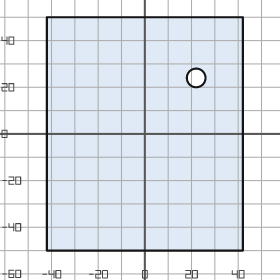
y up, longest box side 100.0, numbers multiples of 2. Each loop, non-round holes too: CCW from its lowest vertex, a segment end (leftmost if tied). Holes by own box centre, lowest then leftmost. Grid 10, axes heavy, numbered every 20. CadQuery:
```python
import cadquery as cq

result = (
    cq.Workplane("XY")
    .moveTo(-42.0, -50.0)
    .lineTo(42.0, -50.0)
    .lineTo(42.0, 50.0)
    .lineTo(-42.0, 50.0)
    .close()
    .moveTo(22.0, 24.0)
    .circle(4.0)
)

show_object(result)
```